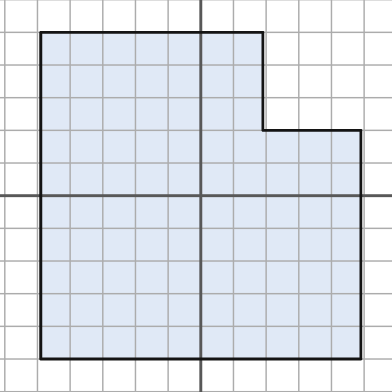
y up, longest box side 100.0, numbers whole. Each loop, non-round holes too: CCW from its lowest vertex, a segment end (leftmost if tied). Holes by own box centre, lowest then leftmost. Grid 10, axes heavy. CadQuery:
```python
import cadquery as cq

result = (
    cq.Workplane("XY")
    .moveTo(-49.0, -50.0)
    .lineTo(49.0, -50.0)
    .lineTo(49.0, 20.0)
    .lineTo(19.0, 20.0)
    .lineTo(19.0, 50.0)
    .lineTo(-49.0, 50.0)
    .close()
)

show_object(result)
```